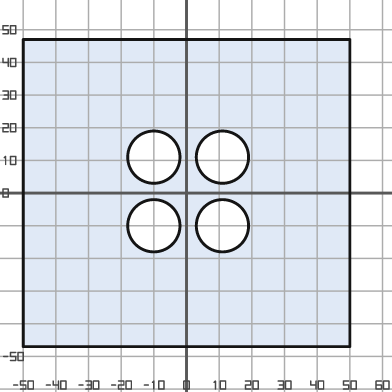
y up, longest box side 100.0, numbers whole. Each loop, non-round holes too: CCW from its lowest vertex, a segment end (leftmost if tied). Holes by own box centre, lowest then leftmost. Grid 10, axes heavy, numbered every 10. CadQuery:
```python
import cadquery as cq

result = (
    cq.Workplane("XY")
    .moveTo(-50.0, -47.0)
    .lineTo(50.0, -47.0)
    .lineTo(50.0, 47.0)
    .lineTo(-50.0, 47.0)
    .close()
    .moveTo(-10.0, -10.0)
    .circle(8.0)
    .moveTo(11.0, -10.0)
    .circle(8.0)
    .moveTo(-10.0, 11.0)
    .circle(8.0)
    .moveTo(11.0, 11.0)
    .circle(8.0)
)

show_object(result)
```